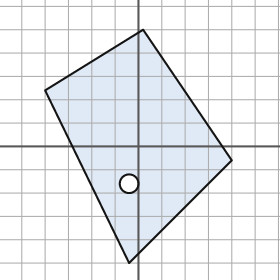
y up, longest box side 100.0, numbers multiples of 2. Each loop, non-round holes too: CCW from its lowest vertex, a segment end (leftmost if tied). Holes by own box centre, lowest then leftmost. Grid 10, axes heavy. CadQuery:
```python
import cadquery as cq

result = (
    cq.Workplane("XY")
    .moveTo(-4.0, -50.0)
    .lineTo(40.0, -6.0)
    .lineTo(2.0, 50.0)
    .lineTo(-40.0, 24.0)
    .close()
    .moveTo(-4.0, -16.0)
    .circle(4.0)
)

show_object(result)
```